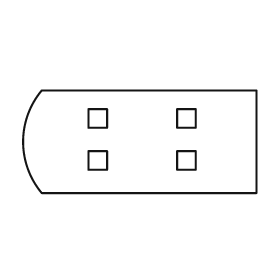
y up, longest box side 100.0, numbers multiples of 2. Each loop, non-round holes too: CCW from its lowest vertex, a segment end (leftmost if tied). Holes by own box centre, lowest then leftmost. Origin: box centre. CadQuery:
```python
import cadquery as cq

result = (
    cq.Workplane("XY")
    .moveTo(-42.0, -22.0)
    .lineTo(50.0, -22.0)
    .lineTo(50.0, 22.0)
    .lineTo(-42.0, 22.0)
    .threePointArc((-50.0, 0.0), (-42.0, -22.0))
    .close()
    .moveTo(-22.0, -12.0)
    .lineTo(-14.0, -12.0)
    .lineTo(-14.0, -4.0)
    .lineTo(-22.0, -4.0)
    .close()
    .moveTo(16.0, -12.0)
    .lineTo(24.0, -12.0)
    .lineTo(24.0, -4.0)
    .lineTo(16.0, -4.0)
    .close()
    .moveTo(-22.0, 6.0)
    .lineTo(-14.0, 6.0)
    .lineTo(-14.0, 14.0)
    .lineTo(-22.0, 14.0)
    .close()
    .moveTo(16.0, 6.0)
    .lineTo(24.0, 6.0)
    .lineTo(24.0, 14.0)
    .lineTo(16.0, 14.0)
    .close()
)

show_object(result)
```